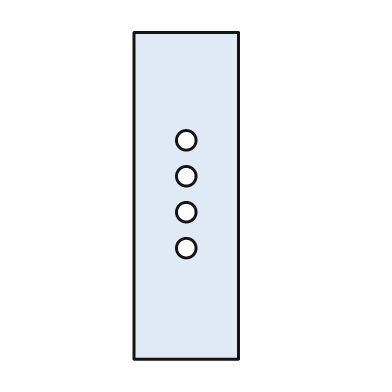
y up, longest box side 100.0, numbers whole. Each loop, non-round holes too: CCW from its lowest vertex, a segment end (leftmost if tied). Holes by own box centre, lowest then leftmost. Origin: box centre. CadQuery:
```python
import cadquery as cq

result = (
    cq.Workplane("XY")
    .moveTo(-16.0, -50.0)
    .lineTo(16.0, -50.0)
    .lineTo(16.0, 50.0)
    .lineTo(-16.0, 50.0)
    .close()
    .moveTo(0.0, -16.0)
    .circle(3.0)
    .moveTo(0.0, -5.0)
    .circle(3.0)
    .moveTo(0.0, 6.0)
    .circle(3.0)
    .moveTo(0.0, 17.0)
    .circle(3.0)
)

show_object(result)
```